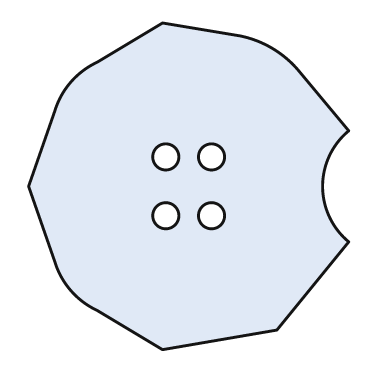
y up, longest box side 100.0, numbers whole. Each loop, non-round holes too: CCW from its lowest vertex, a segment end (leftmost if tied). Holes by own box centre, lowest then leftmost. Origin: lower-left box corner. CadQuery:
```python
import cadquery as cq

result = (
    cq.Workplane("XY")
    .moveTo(41.0, 0.0)
    .lineTo(76.0, 6.0)
    .lineTo(98.0, 33.0)
    .threePointArc((90.0, 50.0), (98.0, 67.0))
    .lineTo(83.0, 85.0)
    .threePointArc((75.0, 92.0), (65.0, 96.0))
    .lineTo(41.0, 100.0)
    .lineTo(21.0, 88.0)
    .threePointArc((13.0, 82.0), (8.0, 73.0))
    .lineTo(0.0, 50.0)
    .lineTo(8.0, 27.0)
    .threePointArc((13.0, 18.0), (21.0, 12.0))
    .close()
    .moveTo(42.0, 41.0)
    .circle(4.0)
    .moveTo(56.0, 41.0)
    .circle(4.0)
    .moveTo(42.0, 59.0)
    .circle(4.0)
    .moveTo(56.0, 59.0)
    .circle(4.0)
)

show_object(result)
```